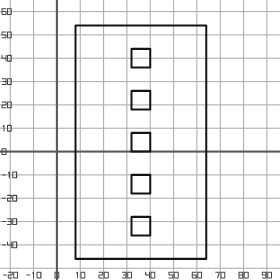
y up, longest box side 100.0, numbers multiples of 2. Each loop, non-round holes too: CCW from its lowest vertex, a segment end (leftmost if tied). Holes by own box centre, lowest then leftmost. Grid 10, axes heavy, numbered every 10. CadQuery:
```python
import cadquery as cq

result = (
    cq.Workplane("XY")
    .moveTo(8.0, -46.0)
    .lineTo(64.0, -46.0)
    .lineTo(64.0, 54.0)
    .lineTo(8.0, 54.0)
    .close()
    .moveTo(32.0, -36.0)
    .lineTo(40.0, -36.0)
    .lineTo(40.0, -28.0)
    .lineTo(32.0, -28.0)
    .close()
    .moveTo(32.0, -18.0)
    .lineTo(40.0, -18.0)
    .lineTo(40.0, -10.0)
    .lineTo(32.0, -10.0)
    .close()
    .moveTo(32.0, 0.0)
    .lineTo(40.0, 0.0)
    .lineTo(40.0, 8.0)
    .lineTo(32.0, 8.0)
    .close()
    .moveTo(32.0, 18.0)
    .lineTo(40.0, 18.0)
    .lineTo(40.0, 26.0)
    .lineTo(32.0, 26.0)
    .close()
    .moveTo(32.0, 36.0)
    .lineTo(40.0, 36.0)
    .lineTo(40.0, 44.0)
    .lineTo(32.0, 44.0)
    .close()
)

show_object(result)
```